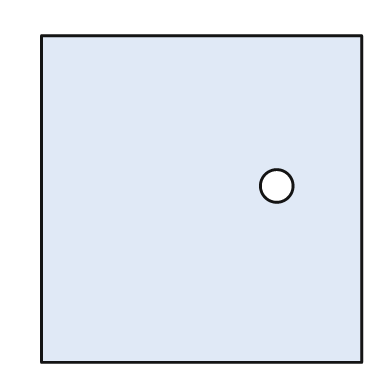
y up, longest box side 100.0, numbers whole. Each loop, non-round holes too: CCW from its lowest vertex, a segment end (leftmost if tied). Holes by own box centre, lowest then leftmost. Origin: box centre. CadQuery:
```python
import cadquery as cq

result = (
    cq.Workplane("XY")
    .moveTo(-49.0, -50.0)
    .lineTo(49.0, -50.0)
    .lineTo(49.0, 50.0)
    .lineTo(-49.0, 50.0)
    .close()
    .moveTo(23.0, 4.0)
    .circle(5.0)
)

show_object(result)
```